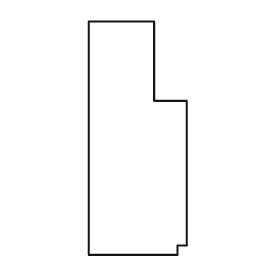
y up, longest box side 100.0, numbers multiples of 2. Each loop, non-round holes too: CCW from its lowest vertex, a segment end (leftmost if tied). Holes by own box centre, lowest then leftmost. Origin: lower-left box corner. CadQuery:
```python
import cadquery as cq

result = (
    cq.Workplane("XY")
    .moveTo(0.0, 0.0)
    .lineTo(38.0, 0.0)
    .lineTo(38.0, 4.0)
    .lineTo(42.0, 4.0)
    .lineTo(42.0, 66.0)
    .lineTo(28.0, 66.0)
    .lineTo(28.0, 100.0)
    .lineTo(0.0, 100.0)
    .close()
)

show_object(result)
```